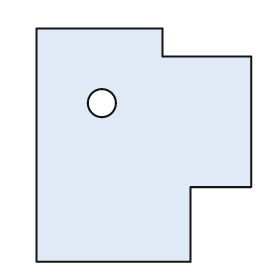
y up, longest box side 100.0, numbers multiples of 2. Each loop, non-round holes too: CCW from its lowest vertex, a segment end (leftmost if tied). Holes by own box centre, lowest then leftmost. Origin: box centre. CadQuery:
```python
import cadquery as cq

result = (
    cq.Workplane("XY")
    .moveTo(-46.0, -50.0)
    .lineTo(20.0, -50.0)
    .lineTo(20.0, -18.0)
    .lineTo(46.0, -18.0)
    .lineTo(46.0, 38.0)
    .lineTo(8.0, 38.0)
    .lineTo(8.0, 50.0)
    .lineTo(-46.0, 50.0)
    .close()
    .moveTo(-18.0, 18.0)
    .circle(6.0)
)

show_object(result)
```